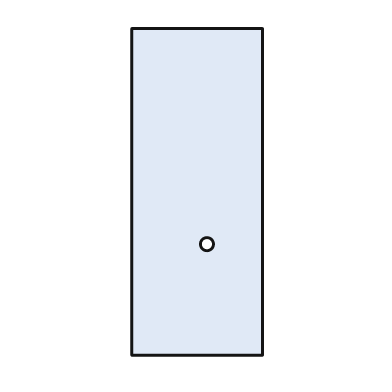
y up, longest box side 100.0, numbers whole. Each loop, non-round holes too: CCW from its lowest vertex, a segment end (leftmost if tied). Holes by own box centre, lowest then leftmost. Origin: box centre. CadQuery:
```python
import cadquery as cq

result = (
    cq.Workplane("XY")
    .moveTo(-20.0, -50.0)
    .lineTo(20.0, -50.0)
    .lineTo(20.0, 50.0)
    .lineTo(-20.0, 50.0)
    .close()
    .moveTo(3.0, -16.0)
    .circle(2.0)
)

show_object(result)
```